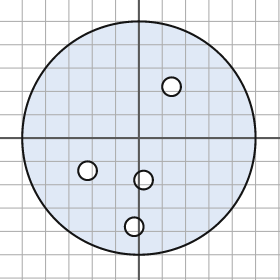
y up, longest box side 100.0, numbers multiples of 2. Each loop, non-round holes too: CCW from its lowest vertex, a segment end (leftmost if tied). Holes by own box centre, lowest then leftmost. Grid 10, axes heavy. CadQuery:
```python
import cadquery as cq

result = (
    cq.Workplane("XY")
    .moveTo(0.0, 0.0)
    .circle(50.0)
    .moveTo(-2.0, -38.0)
    .circle(4.0)
    .moveTo(2.0, -18.0)
    .circle(4.0)
    .moveTo(-22.0, -14.0)
    .circle(4.0)
    .moveTo(14.0, 22.0)
    .circle(4.0)
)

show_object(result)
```